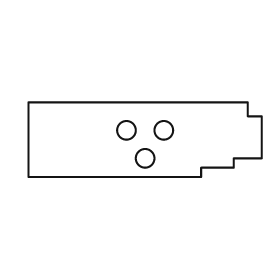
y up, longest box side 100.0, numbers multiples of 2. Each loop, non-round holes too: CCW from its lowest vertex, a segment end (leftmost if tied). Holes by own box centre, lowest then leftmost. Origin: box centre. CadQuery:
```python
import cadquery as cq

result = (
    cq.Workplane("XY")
    .moveTo(-50.0, -16.0)
    .lineTo(24.0, -16.0)
    .lineTo(24.0, -12.0)
    .lineTo(38.0, -12.0)
    .lineTo(38.0, -8.0)
    .lineTo(50.0, -8.0)
    .lineTo(50.0, 10.0)
    .lineTo(44.0, 10.0)
    .lineTo(44.0, 16.0)
    .lineTo(-50.0, 16.0)
    .close()
    .moveTo(0.0, -8.0)
    .circle(4.0)
    .moveTo(-8.0, 4.0)
    .circle(4.0)
    .moveTo(8.0, 4.0)
    .circle(4.0)
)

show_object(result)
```